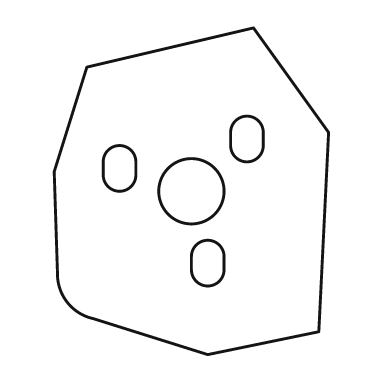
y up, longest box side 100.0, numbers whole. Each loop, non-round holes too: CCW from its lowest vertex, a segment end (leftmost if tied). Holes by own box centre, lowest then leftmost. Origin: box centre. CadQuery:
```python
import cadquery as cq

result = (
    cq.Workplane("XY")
    .moveTo(5.0, -50.0)
    .lineTo(39.0, -43.0)
    .lineTo(42.0, 18.0)
    .lineTo(19.0, 50.0)
    .lineTo(-32.0, 38.0)
    .lineTo(-42.0, 6.0)
    .lineTo(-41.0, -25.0)
    .threePointArc((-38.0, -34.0), (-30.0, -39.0))
    .close()
    .moveTo(0.0, -24.0)
    .threePointArc((5.0, -29.0), (10.0, -24.0))
    .lineTo(10.0, -20.0)
    .threePointArc((5.0, -15.0), (0.0, -20.0))
    .close()
    .moveTo(0.0, 0.0)
    .circle(10.0)
    .moveTo(-27.0, 5.0)
    .threePointArc((-22.0, 0.0), (-17.0, 5.0))
    .lineTo(-17.0, 9.0)
    .threePointArc((-22.0, 14.0), (-27.0, 9.0))
    .close()
    .moveTo(12.0, 14.0)
    .threePointArc((17.0, 9.0), (22.0, 14.0))
    .lineTo(22.0, 18.0)
    .threePointArc((17.0, 23.0), (12.0, 18.0))
    .close()
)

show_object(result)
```